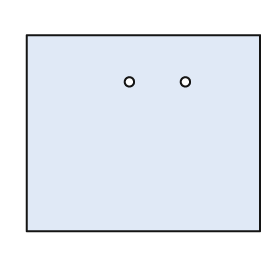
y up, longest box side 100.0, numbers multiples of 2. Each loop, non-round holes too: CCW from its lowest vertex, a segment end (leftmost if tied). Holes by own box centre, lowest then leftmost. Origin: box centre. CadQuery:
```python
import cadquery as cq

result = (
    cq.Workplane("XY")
    .moveTo(-50.0, -42.0)
    .lineTo(50.0, -42.0)
    .lineTo(50.0, 42.0)
    .lineTo(-50.0, 42.0)
    .close()
    .moveTo(-6.0, 22.0)
    .circle(2.0)
    .moveTo(18.0, 22.0)
    .circle(2.0)
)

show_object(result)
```